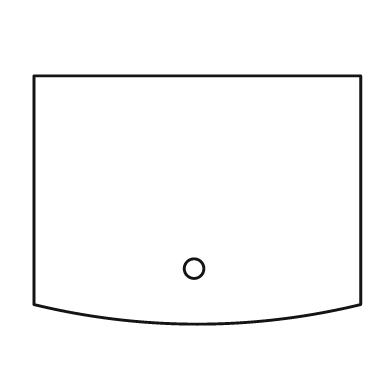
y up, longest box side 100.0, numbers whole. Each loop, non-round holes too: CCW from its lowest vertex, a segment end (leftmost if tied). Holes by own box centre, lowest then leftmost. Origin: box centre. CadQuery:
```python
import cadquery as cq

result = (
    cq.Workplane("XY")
    .moveTo(-50.0, -32.0)
    .threePointArc((0.0, -38.0), (50.0, -32.0))
    .lineTo(50.0, 38.0)
    .lineTo(-50.0, 38.0)
    .close()
    .moveTo(-1.0, -21.0)
    .circle(3.0)
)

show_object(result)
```